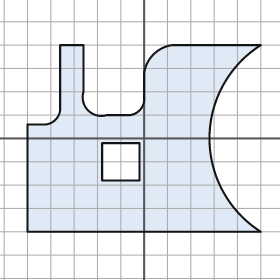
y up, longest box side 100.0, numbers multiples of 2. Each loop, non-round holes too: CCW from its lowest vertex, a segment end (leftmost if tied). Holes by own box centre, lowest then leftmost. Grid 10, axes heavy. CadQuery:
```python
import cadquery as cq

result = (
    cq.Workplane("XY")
    .moveTo(-50.0, -40.0)
    .lineTo(50.0, -40.0)
    .threePointArc((28.0, 0.0), (50.0, 40.0))
    .lineTo(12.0, 40.0)
    .threePointArc((4.0, 36.0), (0.0, 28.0))
    .lineTo(0.0, 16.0)
    .threePointArc((-2.0, 12.0), (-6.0, 10.0))
    .lineTo(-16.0, 10.0)
    .threePointArc((-24.0, 12.0), (-26.0, 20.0))
    .lineTo(-26.0, 40.0)
    .lineTo(-36.0, 40.0)
    .lineTo(-36.0, 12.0)
    .threePointArc((-38.0, 8.0), (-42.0, 6.0))
    .lineTo(-50.0, 6.0)
    .close()
    .moveTo(-18.0, -18.0)
    .lineTo(-2.0, -18.0)
    .lineTo(-2.0, -2.0)
    .lineTo(-18.0, -2.0)
    .close()
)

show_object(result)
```